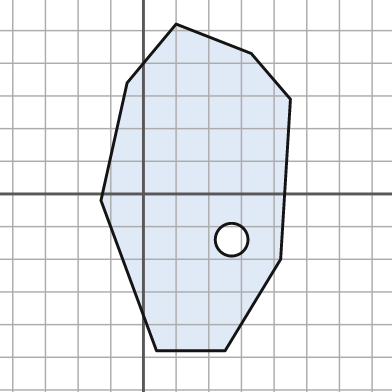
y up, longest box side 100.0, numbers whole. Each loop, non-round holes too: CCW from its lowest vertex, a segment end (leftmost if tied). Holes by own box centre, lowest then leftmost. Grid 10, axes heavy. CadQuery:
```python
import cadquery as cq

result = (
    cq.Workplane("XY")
    .moveTo(4.0, -48.0)
    .lineTo(25.0, -48.0)
    .lineTo(42.0, -20.0)
    .lineTo(45.0, 29.0)
    .lineTo(33.0, 43.0)
    .lineTo(10.0, 52.0)
    .lineTo(-5.0, 34.0)
    .lineTo(-13.0, -2.0)
    .close()
    .moveTo(27.0, -14.0)
    .circle(5.0)
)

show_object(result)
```